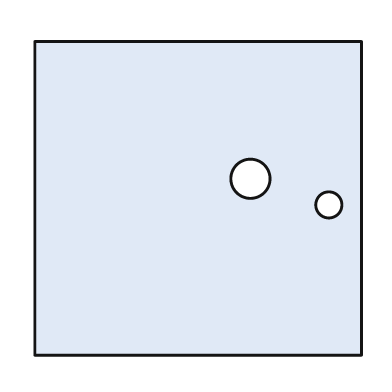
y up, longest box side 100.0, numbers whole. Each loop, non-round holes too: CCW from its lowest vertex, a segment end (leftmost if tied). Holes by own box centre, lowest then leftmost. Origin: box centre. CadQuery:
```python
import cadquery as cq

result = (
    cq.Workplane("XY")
    .moveTo(-50.0, -48.0)
    .lineTo(50.0, -48.0)
    .lineTo(50.0, 48.0)
    .lineTo(-50.0, 48.0)
    .close()
    .moveTo(40.0, -2.0)
    .circle(4.0)
    .moveTo(16.0, 6.0)
    .circle(6.0)
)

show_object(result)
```